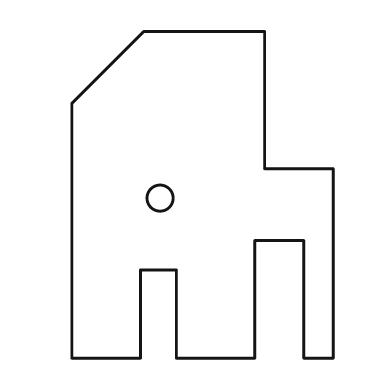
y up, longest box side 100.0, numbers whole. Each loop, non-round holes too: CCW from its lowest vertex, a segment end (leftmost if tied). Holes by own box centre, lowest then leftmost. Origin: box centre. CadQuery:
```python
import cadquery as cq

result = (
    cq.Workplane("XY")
    .moveTo(-40.0, -50.0)
    .lineTo(-19.0, -50.0)
    .lineTo(-19.0, -23.0)
    .lineTo(-8.0, -23.0)
    .lineTo(-8.0, -50.0)
    .lineTo(16.0, -50.0)
    .lineTo(16.0, -14.0)
    .lineTo(31.0, -14.0)
    .lineTo(31.0, -50.0)
    .lineTo(40.0, -50.0)
    .lineTo(40.0, 8.0)
    .lineTo(19.0, 8.0)
    .lineTo(19.0, 50.0)
    .lineTo(-18.0, 50.0)
    .lineTo(-40.0, 28.0)
    .close()
    .moveTo(-13.0, -1.0)
    .circle(4.0)
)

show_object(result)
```